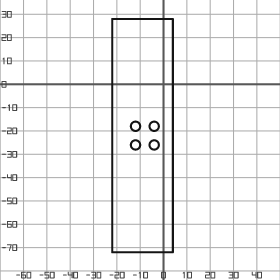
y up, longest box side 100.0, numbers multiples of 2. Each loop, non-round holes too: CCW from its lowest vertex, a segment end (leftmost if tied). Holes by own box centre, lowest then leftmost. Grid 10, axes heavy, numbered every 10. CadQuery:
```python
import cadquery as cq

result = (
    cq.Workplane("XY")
    .moveTo(-22.0, -72.0)
    .lineTo(4.0, -72.0)
    .lineTo(4.0, 28.0)
    .lineTo(-22.0, 28.0)
    .close()
    .moveTo(-12.0, -26.0)
    .circle(2.0)
    .moveTo(-4.0, -26.0)
    .circle(2.0)
    .moveTo(-12.0, -18.0)
    .circle(2.0)
    .moveTo(-4.0, -18.0)
    .circle(2.0)
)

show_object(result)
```